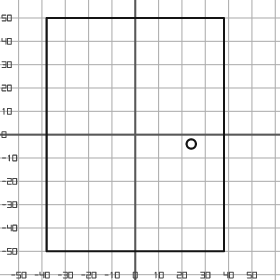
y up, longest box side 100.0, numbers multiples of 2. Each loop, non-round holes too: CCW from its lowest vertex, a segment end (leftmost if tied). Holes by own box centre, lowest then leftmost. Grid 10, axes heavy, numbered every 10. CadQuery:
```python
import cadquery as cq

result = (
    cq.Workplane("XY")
    .moveTo(-38.0, -50.0)
    .lineTo(38.0, -50.0)
    .lineTo(38.0, 50.0)
    .lineTo(-38.0, 50.0)
    .close()
    .moveTo(24.0, -4.0)
    .circle(2.0)
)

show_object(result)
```